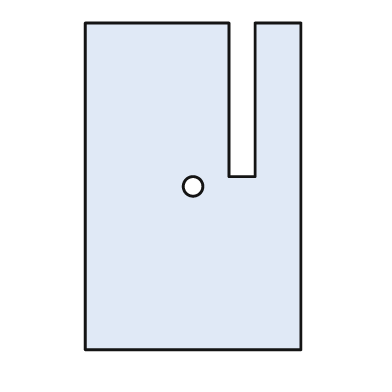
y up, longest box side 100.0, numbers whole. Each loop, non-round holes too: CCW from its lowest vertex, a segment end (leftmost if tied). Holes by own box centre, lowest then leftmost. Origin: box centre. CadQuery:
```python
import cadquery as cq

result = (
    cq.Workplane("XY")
    .moveTo(-33.0, -50.0)
    .lineTo(33.0, -50.0)
    .lineTo(33.0, 50.0)
    .lineTo(19.0, 50.0)
    .lineTo(19.0, 3.0)
    .lineTo(11.0, 3.0)
    .lineTo(11.0, 50.0)
    .lineTo(-33.0, 50.0)
    .close()
    .moveTo(0.0, 0.0)
    .circle(3.0)
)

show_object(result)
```